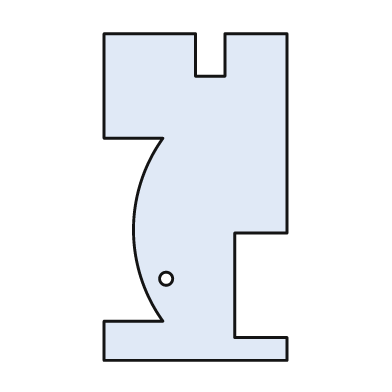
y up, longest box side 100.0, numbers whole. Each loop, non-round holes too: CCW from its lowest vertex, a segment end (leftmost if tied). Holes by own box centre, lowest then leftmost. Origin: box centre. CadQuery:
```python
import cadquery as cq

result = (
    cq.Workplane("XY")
    .moveTo(-28.0, -50.0)
    .lineTo(28.0, -50.0)
    .lineTo(28.0, -43.0)
    .lineTo(12.0, -43.0)
    .lineTo(12.0, -11.0)
    .lineTo(28.0, -11.0)
    .lineTo(28.0, 50.0)
    .lineTo(9.0, 50.0)
    .lineTo(9.0, 37.0)
    .lineTo(0.0, 37.0)
    .lineTo(0.0, 50.0)
    .lineTo(-28.0, 50.0)
    .lineTo(-28.0, 18.0)
    .lineTo(-10.0, 18.0)
    .threePointArc((-19.0, -10.0), (-10.0, -38.0))
    .lineTo(-28.0, -38.0)
    .close()
    .moveTo(-9.0, -25.0)
    .circle(2.0)
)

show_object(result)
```